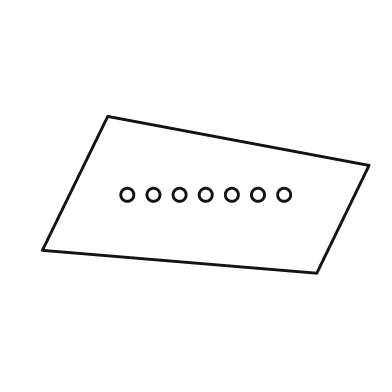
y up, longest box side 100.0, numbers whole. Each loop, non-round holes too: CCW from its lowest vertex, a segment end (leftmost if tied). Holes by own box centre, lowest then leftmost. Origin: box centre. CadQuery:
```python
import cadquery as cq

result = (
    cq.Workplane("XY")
    .moveTo(34.0, -24.0)
    .lineTo(50.0, 9.0)
    .lineTo(-30.0, 24.0)
    .lineTo(-50.0, -17.0)
    .close()
    .moveTo(-24.0, 0.0)
    .circle(2.0)
    .moveTo(-16.0, 0.0)
    .circle(2.0)
    .moveTo(-8.0, 0.0)
    .circle(2.0)
    .moveTo(0.0, 0.0)
    .circle(2.0)
    .moveTo(8.0, 0.0)
    .circle(2.0)
    .moveTo(16.0, 0.0)
    .circle(2.0)
    .moveTo(24.0, 0.0)
    .circle(2.0)
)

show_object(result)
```